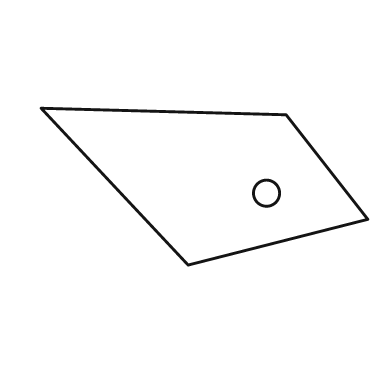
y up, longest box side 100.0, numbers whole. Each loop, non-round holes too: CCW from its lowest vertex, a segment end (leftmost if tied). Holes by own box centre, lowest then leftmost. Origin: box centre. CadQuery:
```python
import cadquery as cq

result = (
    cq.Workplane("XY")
    .moveTo(-5.0, -24.0)
    .lineTo(50.0, -10.0)
    .lineTo(25.0, 22.0)
    .lineTo(-50.0, 24.0)
    .close()
    .moveTo(19.0, -2.0)
    .circle(4.0)
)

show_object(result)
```